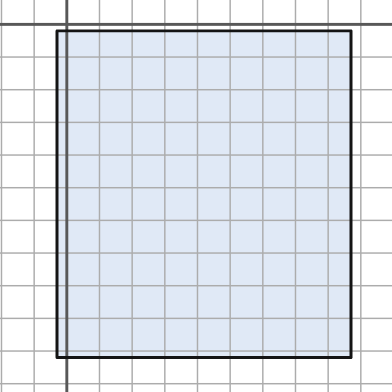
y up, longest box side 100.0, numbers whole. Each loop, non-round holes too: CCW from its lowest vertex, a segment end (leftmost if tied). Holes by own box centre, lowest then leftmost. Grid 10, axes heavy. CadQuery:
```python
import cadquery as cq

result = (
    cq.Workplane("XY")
    .moveTo(-3.0, -102.0)
    .lineTo(87.0, -102.0)
    .lineTo(87.0, -2.0)
    .lineTo(-3.0, -2.0)
    .close()
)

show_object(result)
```